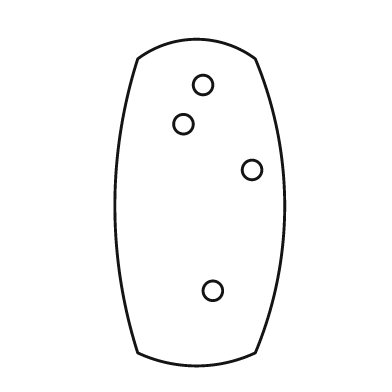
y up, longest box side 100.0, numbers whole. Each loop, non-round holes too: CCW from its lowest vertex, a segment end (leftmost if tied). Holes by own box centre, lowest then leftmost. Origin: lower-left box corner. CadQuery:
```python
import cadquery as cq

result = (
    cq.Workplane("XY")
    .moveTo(7.0, 4.0)
    .threePointArc((25.0, 0.0), (43.0, 4.0))
    .threePointArc((52.0, 49.0), (43.0, 94.0))
    .threePointArc((25.0, 100.0), (7.0, 94.0))
    .threePointArc((0.0, 49.0), (7.0, 4.0))
    .close()
    .moveTo(30.0, 23.0)
    .circle(3.0)
    .moveTo(42.0, 60.0)
    .circle(3.0)
    .moveTo(21.0, 74.0)
    .circle(3.0)
    .moveTo(27.0, 86.0)
    .circle(3.0)
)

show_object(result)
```